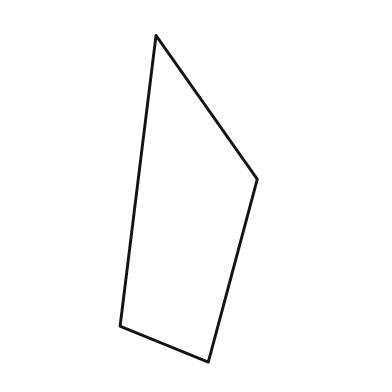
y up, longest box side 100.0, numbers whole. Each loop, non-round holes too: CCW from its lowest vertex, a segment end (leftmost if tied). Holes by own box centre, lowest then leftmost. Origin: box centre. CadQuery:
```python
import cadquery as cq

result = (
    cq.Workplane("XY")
    .moveTo(6.0, -50.0)
    .lineTo(21.0, 6.0)
    .lineTo(-10.0, 50.0)
    .lineTo(-21.0, -39.0)
    .close()
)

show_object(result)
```